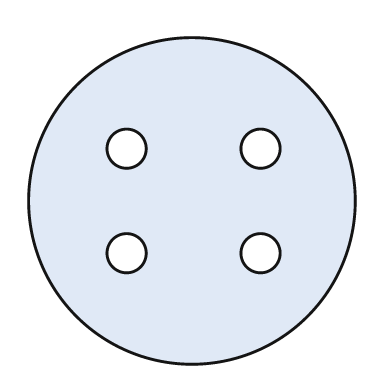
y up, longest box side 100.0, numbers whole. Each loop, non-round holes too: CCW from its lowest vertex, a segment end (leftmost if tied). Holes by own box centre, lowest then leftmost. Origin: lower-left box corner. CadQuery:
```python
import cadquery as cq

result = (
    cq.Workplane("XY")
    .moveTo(50.0, 50.0)
    .circle(50.0)
    .moveTo(30.0, 34.0)
    .circle(6.0)
    .moveTo(71.0, 34.0)
    .circle(6.0)
    .moveTo(30.0, 66.0)
    .circle(6.0)
    .moveTo(71.0, 66.0)
    .circle(6.0)
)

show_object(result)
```